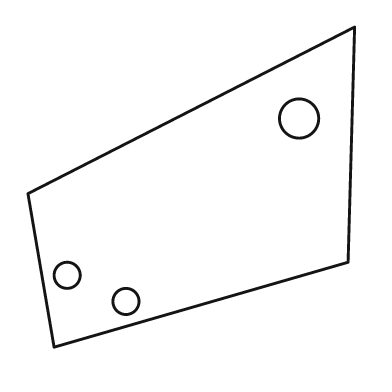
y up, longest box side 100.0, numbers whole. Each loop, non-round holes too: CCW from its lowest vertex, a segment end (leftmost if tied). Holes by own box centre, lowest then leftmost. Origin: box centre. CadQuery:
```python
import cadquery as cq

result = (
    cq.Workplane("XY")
    .moveTo(-42.0, -49.0)
    .lineTo(48.0, -23.0)
    .lineTo(50.0, 49.0)
    .lineTo(-50.0, -2.0)
    .close()
    .moveTo(-20.0, -35.0)
    .circle(4.0)
    .moveTo(-38.0, -27.0)
    .circle(4.0)
    .moveTo(33.0, 21.0)
    .circle(6.0)
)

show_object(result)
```